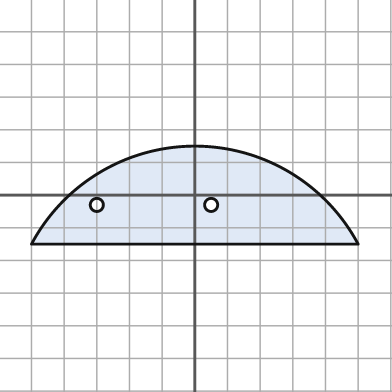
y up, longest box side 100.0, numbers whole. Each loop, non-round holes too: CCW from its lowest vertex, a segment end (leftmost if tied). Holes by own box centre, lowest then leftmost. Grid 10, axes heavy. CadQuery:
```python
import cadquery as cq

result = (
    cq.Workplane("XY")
    .moveTo(-50.0, -15.0)
    .lineTo(50.0, -15.0)
    .threePointArc((0.0, 15.0), (-50.0, -15.0))
    .close()
    .moveTo(-30.0, -3.0)
    .circle(2.0)
    .moveTo(5.0, -3.0)
    .circle(2.0)
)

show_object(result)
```